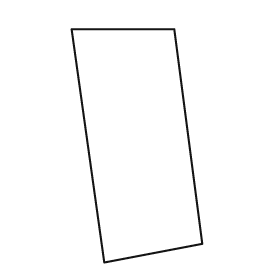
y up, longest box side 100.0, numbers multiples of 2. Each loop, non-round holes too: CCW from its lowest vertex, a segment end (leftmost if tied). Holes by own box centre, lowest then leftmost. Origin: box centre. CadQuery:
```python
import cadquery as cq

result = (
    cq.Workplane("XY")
    .moveTo(-14.0, -50.0)
    .lineTo(28.0, -42.0)
    .lineTo(16.0, 50.0)
    .lineTo(-28.0, 50.0)
    .close()
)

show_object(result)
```